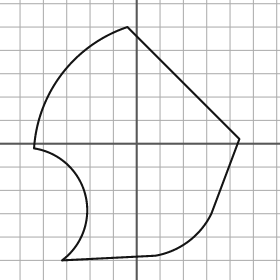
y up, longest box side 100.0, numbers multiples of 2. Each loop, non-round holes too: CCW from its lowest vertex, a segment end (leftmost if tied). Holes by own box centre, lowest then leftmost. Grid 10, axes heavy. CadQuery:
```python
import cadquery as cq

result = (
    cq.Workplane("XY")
    .moveTo(-32.0, -50.0)
    .lineTo(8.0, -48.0)
    .threePointArc((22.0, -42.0), (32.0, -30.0))
    .lineTo(44.0, 2.0)
    .lineTo(-4.0, 50.0)
    .threePointArc((-32.0, 30.0), (-44.0, -2.0))
    .threePointArc((-22.0, -22.0), (-32.0, -50.0))
    .close()
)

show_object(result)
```